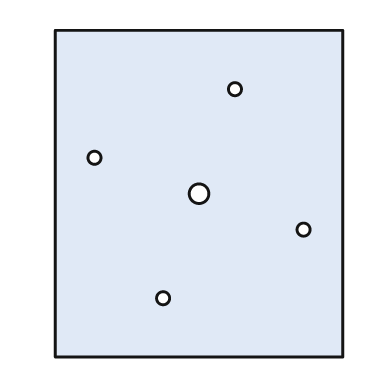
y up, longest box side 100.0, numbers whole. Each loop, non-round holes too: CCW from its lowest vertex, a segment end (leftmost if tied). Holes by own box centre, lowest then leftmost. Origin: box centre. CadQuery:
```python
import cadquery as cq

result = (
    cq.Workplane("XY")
    .moveTo(-44.0, -50.0)
    .lineTo(44.0, -50.0)
    .lineTo(44.0, 50.0)
    .lineTo(-44.0, 50.0)
    .close()
    .moveTo(-11.0, -32.0)
    .circle(2.0)
    .moveTo(32.0, -11.0)
    .circle(2.0)
    .moveTo(0.0, 0.0)
    .circle(3.0)
    .moveTo(-32.0, 11.0)
    .circle(2.0)
    .moveTo(11.0, 32.0)
    .circle(2.0)
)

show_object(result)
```